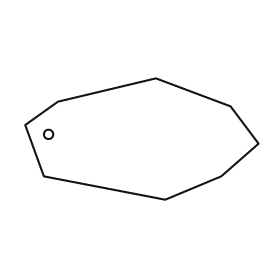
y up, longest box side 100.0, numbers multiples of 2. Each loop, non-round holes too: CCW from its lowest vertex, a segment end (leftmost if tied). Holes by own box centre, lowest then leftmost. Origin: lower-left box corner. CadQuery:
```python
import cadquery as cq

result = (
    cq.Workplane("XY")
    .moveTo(60.0, 0.0)
    .lineTo(84.0, 10.0)
    .lineTo(100.0, 24.0)
    .lineTo(88.0, 40.0)
    .lineTo(56.0, 52.0)
    .lineTo(14.0, 42.0)
    .lineTo(0.0, 32.0)
    .lineTo(8.0, 10.0)
    .close()
    .moveTo(10.0, 28.0)
    .circle(2.0)
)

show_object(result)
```